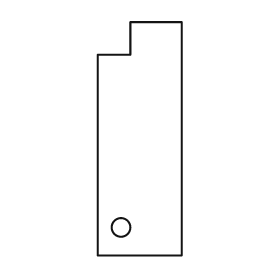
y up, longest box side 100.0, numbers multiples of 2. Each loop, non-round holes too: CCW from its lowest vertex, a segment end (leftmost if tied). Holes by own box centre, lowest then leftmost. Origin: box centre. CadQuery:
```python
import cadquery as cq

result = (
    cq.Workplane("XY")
    .moveTo(-18.0, -50.0)
    .lineTo(18.0, -50.0)
    .lineTo(18.0, 50.0)
    .lineTo(-4.0, 50.0)
    .lineTo(-4.0, 36.0)
    .lineTo(-18.0, 36.0)
    .close()
    .moveTo(-8.0, -38.0)
    .circle(4.0)
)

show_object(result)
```